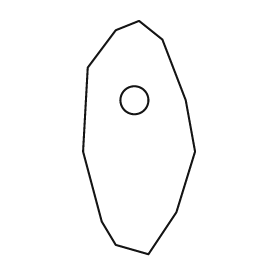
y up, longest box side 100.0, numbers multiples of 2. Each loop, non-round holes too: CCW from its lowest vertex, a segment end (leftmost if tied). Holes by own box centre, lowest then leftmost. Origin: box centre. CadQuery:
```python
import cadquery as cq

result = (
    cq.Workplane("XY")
    .moveTo(4.0, -50.0)
    .lineTo(16.0, -32.0)
    .lineTo(24.0, -6.0)
    .lineTo(20.0, 16.0)
    .lineTo(10.0, 42.0)
    .lineTo(0.0, 50.0)
    .lineTo(-10.0, 46.0)
    .lineTo(-22.0, 30.0)
    .lineTo(-24.0, -6.0)
    .lineTo(-16.0, -36.0)
    .lineTo(-10.0, -46.0)
    .close()
    .moveTo(-2.0, 16.0)
    .circle(6.0)
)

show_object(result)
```